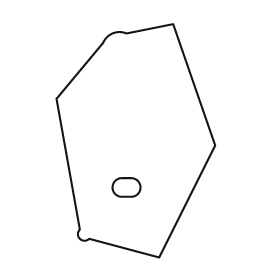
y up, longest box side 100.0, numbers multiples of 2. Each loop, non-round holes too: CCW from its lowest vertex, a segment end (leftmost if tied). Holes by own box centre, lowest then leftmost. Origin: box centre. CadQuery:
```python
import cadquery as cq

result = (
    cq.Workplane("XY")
    .moveTo(10.0, -50.0)
    .lineTo(34.0, -2.0)
    .lineTo(16.0, 50.0)
    .lineTo(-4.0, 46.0)
    .threePointArc((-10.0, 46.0), (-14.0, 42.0))
    .lineTo(-34.0, 18.0)
    .lineTo(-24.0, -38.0)
    .threePointArc((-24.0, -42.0), (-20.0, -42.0))
    .close()
    .moveTo(-6.0, -24.0)
    .lineTo(-2.0, -24.0)
    .threePointArc((2.0, -20.0), (-2.0, -16.0))
    .lineTo(-6.0, -16.0)
    .threePointArc((-10.0, -20.0), (-6.0, -24.0))
    .close()
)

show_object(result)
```